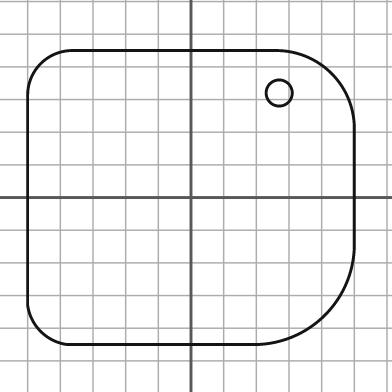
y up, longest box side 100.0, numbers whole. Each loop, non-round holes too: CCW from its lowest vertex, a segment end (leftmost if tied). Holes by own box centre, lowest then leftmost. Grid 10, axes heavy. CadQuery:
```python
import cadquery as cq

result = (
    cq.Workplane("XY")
    .moveTo(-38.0, -45.0)
    .lineTo(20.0, -45.0)
    .threePointArc((41.0, -36.0), (50.0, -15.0))
    .lineTo(50.0, 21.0)
    .threePointArc((43.0, 38.0), (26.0, 45.0))
    .lineTo(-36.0, 45.0)
    .threePointArc((-46.0, 41.0), (-50.0, 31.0))
    .lineTo(-50.0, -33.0)
    .threePointArc((-46.0, -41.0), (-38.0, -45.0))
    .close()
    .moveTo(27.0, 32.0)
    .circle(4.0)
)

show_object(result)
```